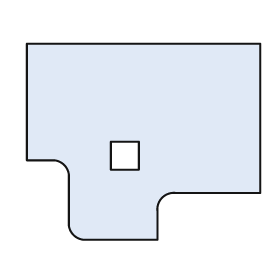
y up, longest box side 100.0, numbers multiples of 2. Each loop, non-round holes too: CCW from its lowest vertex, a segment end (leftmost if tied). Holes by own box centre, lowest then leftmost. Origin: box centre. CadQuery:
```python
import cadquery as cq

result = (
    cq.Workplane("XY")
    .moveTo(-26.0, -42.0)
    .lineTo(6.0, -42.0)
    .lineTo(6.0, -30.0)
    .threePointArc((8.0, -24.0), (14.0, -22.0))
    .lineTo(50.0, -22.0)
    .lineTo(50.0, 42.0)
    .lineTo(-50.0, 42.0)
    .lineTo(-50.0, -8.0)
    .lineTo(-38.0, -8.0)
    .threePointArc((-34.0, -10.0), (-32.0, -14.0))
    .lineTo(-32.0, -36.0)
    .threePointArc((-30.0, -40.0), (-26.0, -42.0))
    .close()
    .moveTo(-14.0, -12.0)
    .lineTo(-2.0, -12.0)
    .lineTo(-2.0, 0.0)
    .lineTo(-14.0, 0.0)
    .close()
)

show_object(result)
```